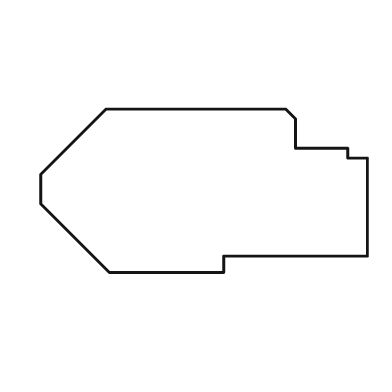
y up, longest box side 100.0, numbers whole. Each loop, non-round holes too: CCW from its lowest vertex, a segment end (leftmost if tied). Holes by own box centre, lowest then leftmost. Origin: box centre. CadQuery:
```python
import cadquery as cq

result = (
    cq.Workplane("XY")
    .moveTo(-29.0, -25.0)
    .lineTo(6.0, -25.0)
    .lineTo(6.0, -20.0)
    .lineTo(50.0, -20.0)
    .lineTo(50.0, 10.0)
    .lineTo(44.0, 10.0)
    .lineTo(44.0, 13.0)
    .lineTo(28.0, 13.0)
    .lineTo(28.0, 22.0)
    .lineTo(25.0, 25.0)
    .lineTo(-30.0, 25.0)
    .lineTo(-50.0, 5.0)
    .lineTo(-50.0, -4.0)
    .close()
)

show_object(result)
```